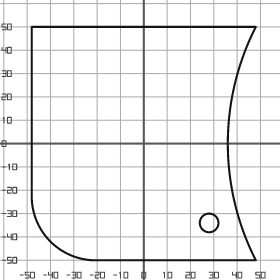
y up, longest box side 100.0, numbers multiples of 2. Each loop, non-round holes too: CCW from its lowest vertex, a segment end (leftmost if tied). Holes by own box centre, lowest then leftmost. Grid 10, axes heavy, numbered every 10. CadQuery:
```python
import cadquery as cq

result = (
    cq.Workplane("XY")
    .moveTo(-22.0, -50.0)
    .lineTo(48.0, -50.0)
    .threePointArc((36.0, 0.0), (48.0, 50.0))
    .lineTo(-48.0, 50.0)
    .lineTo(-48.0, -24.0)
    .threePointArc((-40.0, -42.0), (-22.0, -50.0))
    .close()
    .moveTo(28.0, -34.0)
    .circle(4.0)
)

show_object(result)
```